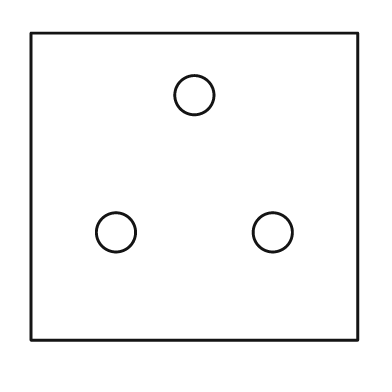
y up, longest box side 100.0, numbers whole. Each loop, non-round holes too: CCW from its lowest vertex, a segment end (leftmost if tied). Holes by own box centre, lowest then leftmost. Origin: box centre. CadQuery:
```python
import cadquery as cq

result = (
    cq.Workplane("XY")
    .moveTo(-50.0, -47.0)
    .lineTo(50.0, -47.0)
    .lineTo(50.0, 47.0)
    .lineTo(-50.0, 47.0)
    .close()
    .moveTo(-24.0, -14.0)
    .circle(6.0)
    .moveTo(24.0, -14.0)
    .circle(6.0)
    .moveTo(0.0, 28.0)
    .circle(6.0)
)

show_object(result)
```